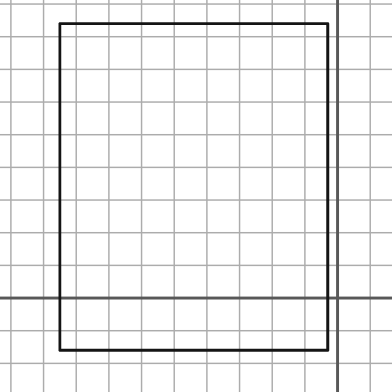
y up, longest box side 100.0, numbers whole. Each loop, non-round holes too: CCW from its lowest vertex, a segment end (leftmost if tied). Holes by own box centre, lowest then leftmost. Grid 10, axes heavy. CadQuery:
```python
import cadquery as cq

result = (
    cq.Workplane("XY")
    .moveTo(-85.0, -16.0)
    .lineTo(-3.0, -16.0)
    .lineTo(-3.0, 84.0)
    .lineTo(-85.0, 84.0)
    .close()
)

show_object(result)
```